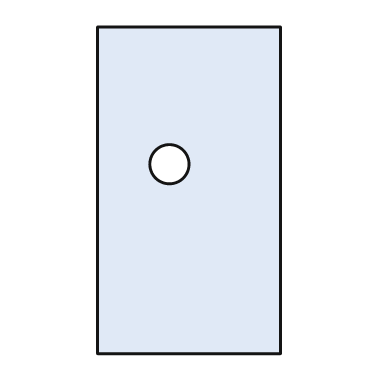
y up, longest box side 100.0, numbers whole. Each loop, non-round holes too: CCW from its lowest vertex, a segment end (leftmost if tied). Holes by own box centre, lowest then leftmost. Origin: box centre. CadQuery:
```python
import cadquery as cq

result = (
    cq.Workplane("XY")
    .moveTo(-28.0, -50.0)
    .lineTo(28.0, -50.0)
    .lineTo(28.0, 50.0)
    .lineTo(-28.0, 50.0)
    .close()
    .moveTo(-6.0, 8.0)
    .circle(6.0)
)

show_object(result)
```